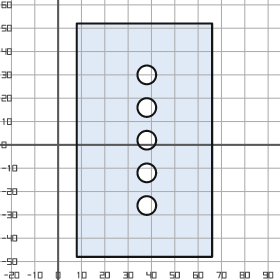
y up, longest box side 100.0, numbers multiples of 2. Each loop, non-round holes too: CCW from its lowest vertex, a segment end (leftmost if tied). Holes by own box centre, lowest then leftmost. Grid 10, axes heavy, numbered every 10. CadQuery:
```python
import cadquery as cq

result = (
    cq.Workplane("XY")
    .moveTo(8.0, -48.0)
    .lineTo(66.0, -48.0)
    .lineTo(66.0, 52.0)
    .lineTo(8.0, 52.0)
    .close()
    .moveTo(38.0, -26.0)
    .circle(4.0)
    .moveTo(38.0, -12.0)
    .circle(4.0)
    .moveTo(38.0, 2.0)
    .circle(4.0)
    .moveTo(38.0, 16.0)
    .circle(4.0)
    .moveTo(38.0, 30.0)
    .circle(4.0)
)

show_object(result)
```